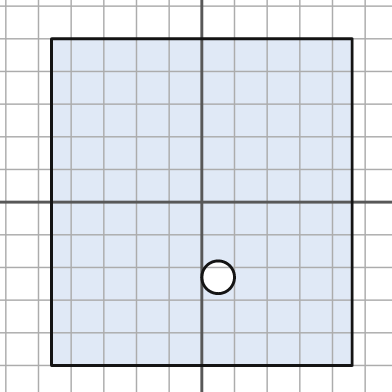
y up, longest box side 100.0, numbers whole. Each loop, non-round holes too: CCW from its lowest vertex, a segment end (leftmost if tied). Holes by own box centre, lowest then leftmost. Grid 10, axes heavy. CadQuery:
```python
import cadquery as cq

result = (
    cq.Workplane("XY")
    .moveTo(-46.0, -50.0)
    .lineTo(46.0, -50.0)
    .lineTo(46.0, 50.0)
    .lineTo(-46.0, 50.0)
    .close()
    .moveTo(5.0, -23.0)
    .circle(5.0)
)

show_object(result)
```